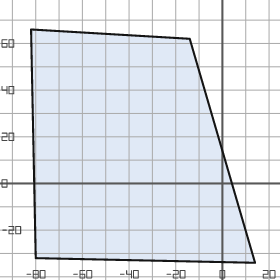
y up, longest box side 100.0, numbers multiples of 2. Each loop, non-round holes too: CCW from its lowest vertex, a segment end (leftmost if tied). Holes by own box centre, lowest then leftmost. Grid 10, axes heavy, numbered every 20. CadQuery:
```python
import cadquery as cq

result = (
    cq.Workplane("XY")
    .moveTo(14.0, -34.0)
    .lineTo(-14.0, 62.0)
    .lineTo(-82.0, 66.0)
    .lineTo(-80.0, -32.0)
    .close()
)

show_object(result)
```